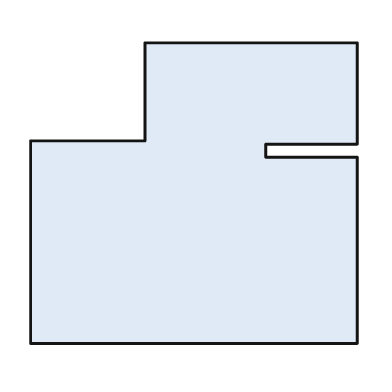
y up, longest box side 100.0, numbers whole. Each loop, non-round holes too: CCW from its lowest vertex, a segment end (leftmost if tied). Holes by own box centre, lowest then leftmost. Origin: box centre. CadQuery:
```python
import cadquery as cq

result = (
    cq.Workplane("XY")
    .moveTo(-50.0, -46.0)
    .lineTo(50.0, -46.0)
    .lineTo(50.0, 11.0)
    .lineTo(22.0, 11.0)
    .lineTo(22.0, 15.0)
    .lineTo(50.0, 15.0)
    .lineTo(50.0, 46.0)
    .lineTo(-15.0, 46.0)
    .lineTo(-15.0, 16.0)
    .lineTo(-50.0, 16.0)
    .close()
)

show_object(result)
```